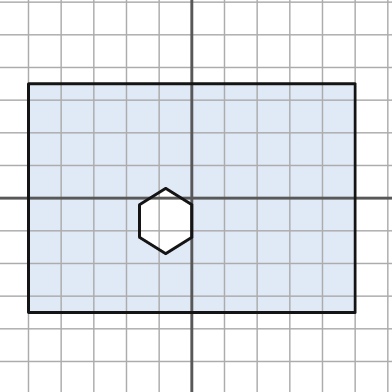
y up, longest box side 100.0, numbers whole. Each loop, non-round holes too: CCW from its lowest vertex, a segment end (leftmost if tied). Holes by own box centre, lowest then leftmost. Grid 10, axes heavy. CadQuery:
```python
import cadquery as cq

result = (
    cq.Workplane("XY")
    .moveTo(-50.0, -35.0)
    .lineTo(50.0, -35.0)
    .lineTo(50.0, 35.0)
    .lineTo(-50.0, 35.0)
    .close()
    .moveTo(-8.0, -17.0)
    .lineTo(0.0, -12.0)
    .lineTo(0.0, -2.0)
    .lineTo(-8.0, 3.0)
    .lineTo(-16.0, -2.0)
    .lineTo(-16.0, -12.0)
    .close()
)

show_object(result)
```